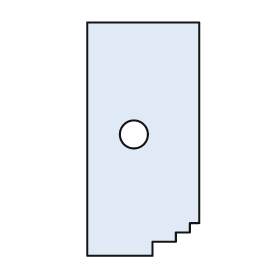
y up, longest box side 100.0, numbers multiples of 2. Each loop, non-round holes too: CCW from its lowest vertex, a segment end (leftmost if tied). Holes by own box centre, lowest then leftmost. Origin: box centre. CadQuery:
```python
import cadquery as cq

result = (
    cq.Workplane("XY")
    .moveTo(-24.0, -50.0)
    .lineTo(4.0, -50.0)
    .lineTo(4.0, -44.0)
    .lineTo(14.0, -44.0)
    .lineTo(14.0, -40.0)
    .lineTo(20.0, -40.0)
    .lineTo(20.0, -36.0)
    .lineTo(24.0, -36.0)
    .lineTo(24.0, 50.0)
    .lineTo(-24.0, 50.0)
    .close()
    .moveTo(-4.0, 2.0)
    .circle(6.0)
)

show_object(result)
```